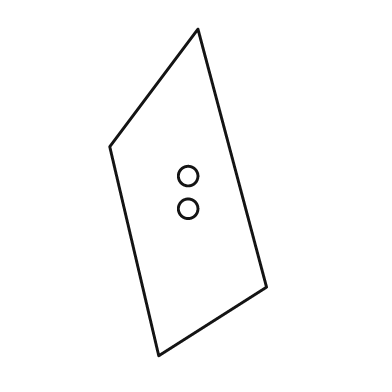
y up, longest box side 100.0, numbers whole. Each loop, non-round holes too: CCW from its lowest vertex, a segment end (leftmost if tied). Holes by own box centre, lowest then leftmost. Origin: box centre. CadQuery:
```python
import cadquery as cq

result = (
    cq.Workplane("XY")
    .moveTo(-9.0, -50.0)
    .lineTo(24.0, -29.0)
    .lineTo(3.0, 50.0)
    .lineTo(-24.0, 14.0)
    .close()
    .moveTo(0.0, -5.0)
    .circle(3.0)
    .moveTo(0.0, 5.0)
    .circle(3.0)
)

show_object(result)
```